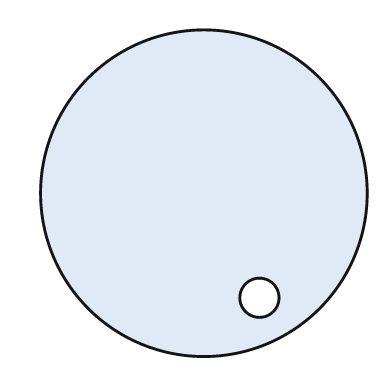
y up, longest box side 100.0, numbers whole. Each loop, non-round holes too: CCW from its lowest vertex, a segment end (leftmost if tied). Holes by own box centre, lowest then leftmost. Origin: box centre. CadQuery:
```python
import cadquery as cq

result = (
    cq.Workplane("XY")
    .moveTo(0.0, 0.0)
    .circle(50.0)
    .moveTo(17.0, -32.0)
    .circle(6.0)
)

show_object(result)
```